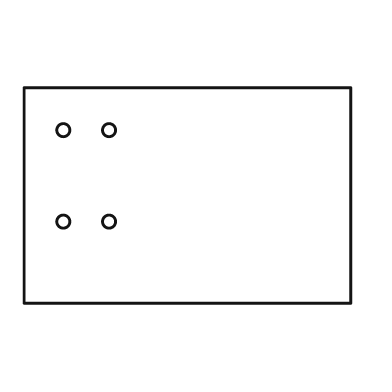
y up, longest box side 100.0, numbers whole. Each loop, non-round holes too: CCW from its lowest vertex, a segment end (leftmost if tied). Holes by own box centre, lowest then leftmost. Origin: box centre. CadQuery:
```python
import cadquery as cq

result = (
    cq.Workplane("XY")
    .moveTo(-50.0, -33.0)
    .lineTo(50.0, -33.0)
    .lineTo(50.0, 33.0)
    .lineTo(-50.0, 33.0)
    .close()
    .moveTo(-38.0, -8.0)
    .circle(2.0)
    .moveTo(-24.0, -8.0)
    .circle(2.0)
    .moveTo(-38.0, 20.0)
    .circle(2.0)
    .moveTo(-24.0, 20.0)
    .circle(2.0)
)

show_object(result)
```